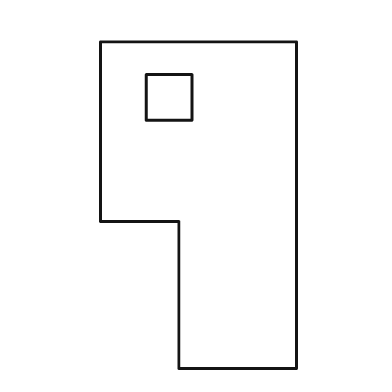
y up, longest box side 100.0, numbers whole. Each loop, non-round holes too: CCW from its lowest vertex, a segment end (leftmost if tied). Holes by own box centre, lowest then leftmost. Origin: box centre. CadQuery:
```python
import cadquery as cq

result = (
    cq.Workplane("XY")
    .moveTo(-6.0, -50.0)
    .lineTo(30.0, -50.0)
    .lineTo(30.0, 50.0)
    .lineTo(-30.0, 50.0)
    .lineTo(-30.0, -5.0)
    .lineTo(-6.0, -5.0)
    .close()
    .moveTo(-16.0, 26.0)
    .lineTo(-2.0, 26.0)
    .lineTo(-2.0, 40.0)
    .lineTo(-16.0, 40.0)
    .close()
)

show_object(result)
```